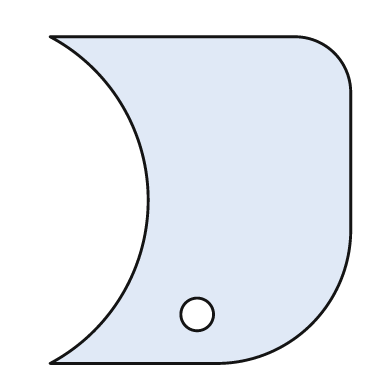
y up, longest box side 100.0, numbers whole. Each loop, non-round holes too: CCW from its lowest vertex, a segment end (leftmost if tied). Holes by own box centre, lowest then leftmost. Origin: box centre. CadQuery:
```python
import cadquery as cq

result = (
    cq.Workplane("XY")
    .moveTo(-46.0, -50.0)
    .lineTo(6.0, -50.0)
    .threePointArc((34.0, -38.0), (46.0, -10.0))
    .lineTo(46.0, 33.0)
    .threePointArc((41.0, 45.0), (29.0, 50.0))
    .lineTo(-46.0, 50.0)
    .threePointArc((-16.0, 0.0), (-46.0, -50.0))
    .close()
    .moveTo(-1.0, -35.0)
    .circle(5.0)
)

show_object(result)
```